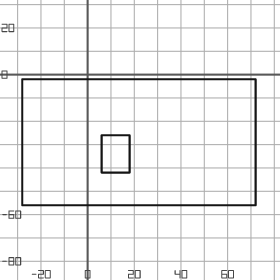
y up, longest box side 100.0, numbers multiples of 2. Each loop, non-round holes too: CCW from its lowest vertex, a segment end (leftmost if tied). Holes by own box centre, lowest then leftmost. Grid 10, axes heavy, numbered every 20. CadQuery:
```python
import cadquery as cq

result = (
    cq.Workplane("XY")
    .moveTo(-28.0, -56.0)
    .lineTo(72.0, -56.0)
    .lineTo(72.0, -2.0)
    .lineTo(-28.0, -2.0)
    .close()
    .moveTo(6.0, -42.0)
    .lineTo(18.0, -42.0)
    .lineTo(18.0, -26.0)
    .lineTo(6.0, -26.0)
    .close()
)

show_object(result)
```